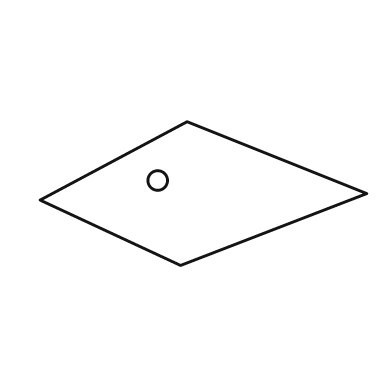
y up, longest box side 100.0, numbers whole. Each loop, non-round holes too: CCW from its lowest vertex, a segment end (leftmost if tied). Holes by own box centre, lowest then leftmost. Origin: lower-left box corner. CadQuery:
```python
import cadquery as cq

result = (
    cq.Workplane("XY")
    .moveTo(43.0, 0.0)
    .lineTo(100.0, 22.0)
    .lineTo(45.0, 44.0)
    .lineTo(0.0, 20.0)
    .close()
    .moveTo(36.0, 26.0)
    .circle(3.0)
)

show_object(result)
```